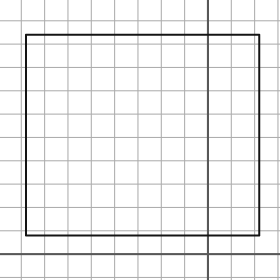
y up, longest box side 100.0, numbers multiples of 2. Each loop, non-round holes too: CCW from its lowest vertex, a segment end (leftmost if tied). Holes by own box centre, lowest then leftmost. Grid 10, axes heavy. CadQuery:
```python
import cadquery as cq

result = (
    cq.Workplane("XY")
    .moveTo(-78.0, 8.0)
    .lineTo(22.0, 8.0)
    .lineTo(22.0, 94.0)
    .lineTo(-78.0, 94.0)
    .close()
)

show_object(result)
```